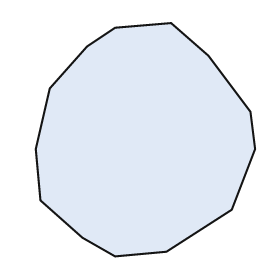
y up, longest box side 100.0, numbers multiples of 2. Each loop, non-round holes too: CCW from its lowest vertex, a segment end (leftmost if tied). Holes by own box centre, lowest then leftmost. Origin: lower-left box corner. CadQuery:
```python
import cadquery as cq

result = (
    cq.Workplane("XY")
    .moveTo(34.0, 0.0)
    .lineTo(56.0, 2.0)
    .lineTo(84.0, 20.0)
    .lineTo(94.0, 46.0)
    .lineTo(92.0, 62.0)
    .lineTo(74.0, 86.0)
    .lineTo(58.0, 100.0)
    .lineTo(34.0, 98.0)
    .lineTo(22.0, 90.0)
    .lineTo(6.0, 72.0)
    .lineTo(0.0, 46.0)
    .lineTo(2.0, 24.0)
    .lineTo(20.0, 8.0)
    .close()
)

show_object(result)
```